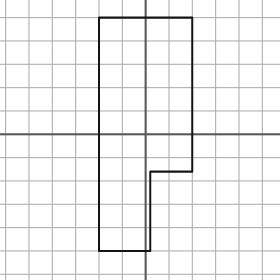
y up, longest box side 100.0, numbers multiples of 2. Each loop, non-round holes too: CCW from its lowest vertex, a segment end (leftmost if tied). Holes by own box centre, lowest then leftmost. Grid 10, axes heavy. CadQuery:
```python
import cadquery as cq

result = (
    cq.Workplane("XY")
    .moveTo(-20.0, -50.0)
    .lineTo(2.0, -50.0)
    .lineTo(2.0, -16.0)
    .lineTo(20.0, -16.0)
    .lineTo(20.0, 50.0)
    .lineTo(-20.0, 50.0)
    .close()
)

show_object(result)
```